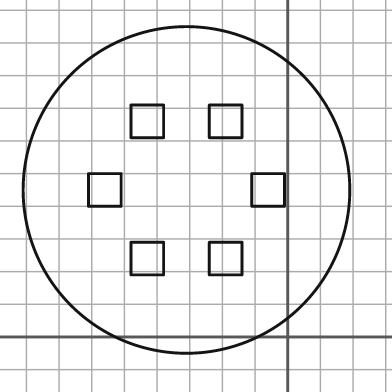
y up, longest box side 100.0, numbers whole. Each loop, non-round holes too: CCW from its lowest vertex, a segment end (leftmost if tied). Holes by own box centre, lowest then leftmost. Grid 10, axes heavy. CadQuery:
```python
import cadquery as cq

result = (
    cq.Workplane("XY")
    .moveTo(-31.0, 45.0)
    .circle(50.0)
    .moveTo(-48.0, 19.0)
    .lineTo(-38.0, 19.0)
    .lineTo(-38.0, 29.0)
    .lineTo(-48.0, 29.0)
    .close()
    .moveTo(-24.0, 19.0)
    .lineTo(-14.0, 19.0)
    .lineTo(-14.0, 29.0)
    .lineTo(-24.0, 29.0)
    .close()
    .moveTo(-61.0, 40.0)
    .lineTo(-51.0, 40.0)
    .lineTo(-51.0, 50.0)
    .lineTo(-61.0, 50.0)
    .close()
    .moveTo(-11.0, 40.0)
    .lineTo(-1.0, 40.0)
    .lineTo(-1.0, 50.0)
    .lineTo(-11.0, 50.0)
    .close()
    .moveTo(-48.0, 61.0)
    .lineTo(-38.0, 61.0)
    .lineTo(-38.0, 71.0)
    .lineTo(-48.0, 71.0)
    .close()
    .moveTo(-24.0, 61.0)
    .lineTo(-14.0, 61.0)
    .lineTo(-14.0, 71.0)
    .lineTo(-24.0, 71.0)
    .close()
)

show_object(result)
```